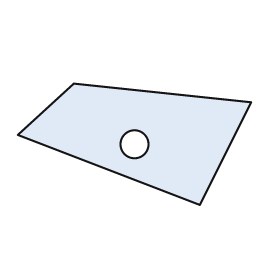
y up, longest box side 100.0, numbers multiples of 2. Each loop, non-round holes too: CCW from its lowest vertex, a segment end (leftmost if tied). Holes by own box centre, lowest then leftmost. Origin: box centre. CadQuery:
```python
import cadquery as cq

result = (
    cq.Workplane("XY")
    .moveTo(28.0, -26.0)
    .lineTo(50.0, 18.0)
    .lineTo(-26.0, 26.0)
    .lineTo(-50.0, 4.0)
    .close()
    .moveTo(0.0, 0.0)
    .circle(6.0)
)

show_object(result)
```